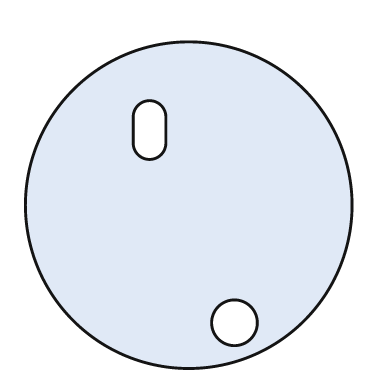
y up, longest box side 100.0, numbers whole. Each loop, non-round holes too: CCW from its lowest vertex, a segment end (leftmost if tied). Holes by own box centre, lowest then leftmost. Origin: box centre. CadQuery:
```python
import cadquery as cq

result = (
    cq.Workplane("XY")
    .moveTo(0.0, 0.0)
    .circle(50.0)
    .moveTo(14.0, -36.0)
    .circle(7.0)
    .moveTo(-17.0, 19.0)
    .threePointArc((-12.0, 14.0), (-7.0, 19.0))
    .lineTo(-7.0, 27.0)
    .threePointArc((-12.0, 32.0), (-17.0, 27.0))
    .close()
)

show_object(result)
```